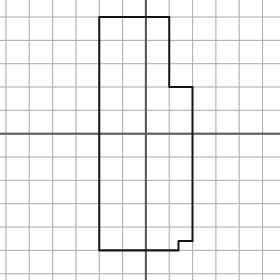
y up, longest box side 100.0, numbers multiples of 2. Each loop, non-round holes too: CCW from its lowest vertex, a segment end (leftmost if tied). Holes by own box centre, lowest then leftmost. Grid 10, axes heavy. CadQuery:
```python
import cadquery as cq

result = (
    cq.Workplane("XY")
    .moveTo(-20.0, -50.0)
    .lineTo(14.0, -50.0)
    .lineTo(14.0, -46.0)
    .lineTo(20.0, -46.0)
    .lineTo(20.0, 20.0)
    .lineTo(10.0, 20.0)
    .lineTo(10.0, 50.0)
    .lineTo(-20.0, 50.0)
    .close()
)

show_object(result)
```